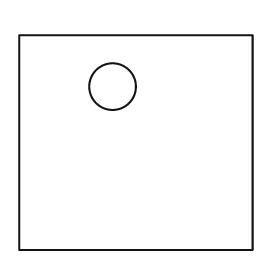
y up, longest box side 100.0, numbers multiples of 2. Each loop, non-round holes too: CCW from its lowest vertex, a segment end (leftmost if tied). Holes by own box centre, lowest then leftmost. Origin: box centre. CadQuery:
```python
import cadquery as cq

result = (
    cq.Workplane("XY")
    .moveTo(-50.0, -46.0)
    .lineTo(50.0, -46.0)
    .lineTo(50.0, 46.0)
    .lineTo(-50.0, 46.0)
    .close()
    .moveTo(-10.0, 24.0)
    .circle(10.0)
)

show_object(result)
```